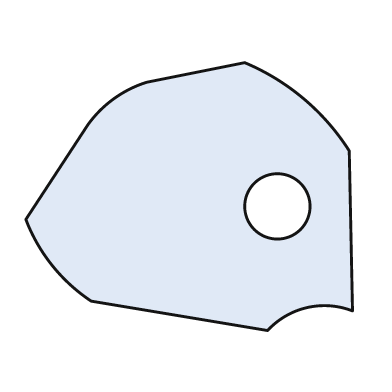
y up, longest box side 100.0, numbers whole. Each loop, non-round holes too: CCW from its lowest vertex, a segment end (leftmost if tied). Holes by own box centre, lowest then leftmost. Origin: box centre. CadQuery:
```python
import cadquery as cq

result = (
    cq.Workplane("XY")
    .moveTo(24.0, -41.0)
    .threePointArc((36.0, -34.0), (50.0, -35.0))
    .lineTo(49.0, 14.0)
    .threePointArc((35.0, 30.0), (17.0, 41.0))
    .lineTo(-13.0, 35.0)
    .threePointArc((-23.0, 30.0), (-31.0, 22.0))
    .lineTo(-50.0, -7.0)
    .threePointArc((-42.0, -21.0), (-30.0, -32.0))
    .close()
    .moveTo(27.0, -3.0)
    .circle(10.0)
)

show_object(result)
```